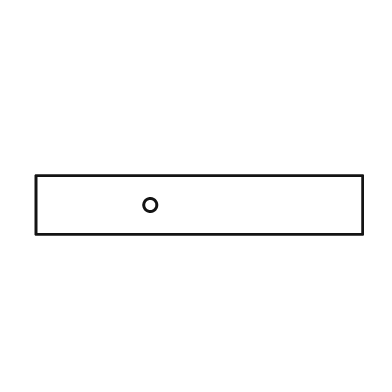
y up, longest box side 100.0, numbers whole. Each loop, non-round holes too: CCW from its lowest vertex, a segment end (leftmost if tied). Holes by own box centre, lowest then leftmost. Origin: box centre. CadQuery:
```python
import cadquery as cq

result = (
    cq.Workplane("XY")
    .moveTo(-50.0, -9.0)
    .lineTo(50.0, -9.0)
    .lineTo(50.0, 9.0)
    .lineTo(-50.0, 9.0)
    .close()
    .moveTo(-15.0, 0.0)
    .circle(2.0)
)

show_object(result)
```